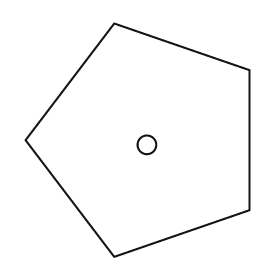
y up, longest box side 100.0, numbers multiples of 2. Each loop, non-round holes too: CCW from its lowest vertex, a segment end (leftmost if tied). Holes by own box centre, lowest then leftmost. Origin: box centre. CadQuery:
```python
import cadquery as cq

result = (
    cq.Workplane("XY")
    .moveTo(-10.0, -50.0)
    .lineTo(48.0, -30.0)
    .lineTo(48.0, 30.0)
    .lineTo(-10.0, 50.0)
    .lineTo(-48.0, 0.0)
    .close()
    .moveTo(4.0, -2.0)
    .circle(4.0)
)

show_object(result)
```